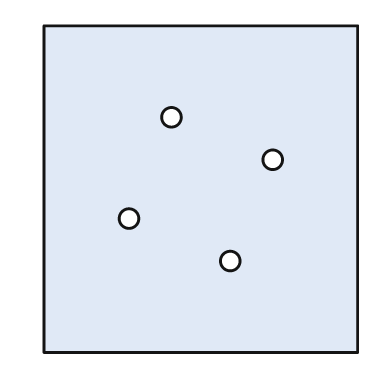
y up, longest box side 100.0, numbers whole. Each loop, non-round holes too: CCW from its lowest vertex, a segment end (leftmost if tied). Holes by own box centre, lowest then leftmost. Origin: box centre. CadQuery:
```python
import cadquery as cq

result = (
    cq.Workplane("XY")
    .moveTo(-48.0, -50.0)
    .lineTo(48.0, -50.0)
    .lineTo(48.0, 50.0)
    .lineTo(-48.0, 50.0)
    .close()
    .moveTo(9.0, -22.0)
    .circle(3.0)
    .moveTo(-22.0, -9.0)
    .circle(3.0)
    .moveTo(22.0, 9.0)
    .circle(3.0)
    .moveTo(-9.0, 22.0)
    .circle(3.0)
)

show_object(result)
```